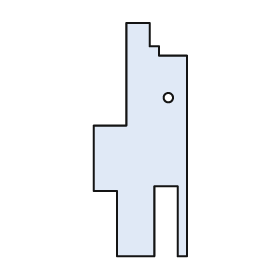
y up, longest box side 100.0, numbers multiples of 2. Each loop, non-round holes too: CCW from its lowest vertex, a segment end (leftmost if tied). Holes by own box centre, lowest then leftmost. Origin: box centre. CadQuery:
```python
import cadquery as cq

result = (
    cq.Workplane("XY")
    .moveTo(-10.0, -50.0)
    .lineTo(6.0, -50.0)
    .lineTo(6.0, -20.0)
    .lineTo(16.0, -20.0)
    .lineTo(16.0, -50.0)
    .lineTo(20.0, -50.0)
    .lineTo(20.0, 36.0)
    .lineTo(8.0, 36.0)
    .lineTo(8.0, 40.0)
    .lineTo(4.0, 40.0)
    .lineTo(4.0, 50.0)
    .lineTo(-6.0, 50.0)
    .lineTo(-6.0, 6.0)
    .lineTo(-20.0, 6.0)
    .lineTo(-20.0, -22.0)
    .lineTo(-10.0, -22.0)
    .close()
    .moveTo(12.0, 18.0)
    .circle(2.0)
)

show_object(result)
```